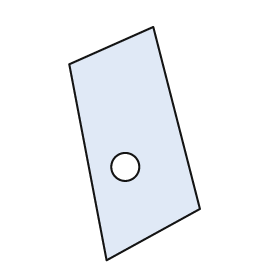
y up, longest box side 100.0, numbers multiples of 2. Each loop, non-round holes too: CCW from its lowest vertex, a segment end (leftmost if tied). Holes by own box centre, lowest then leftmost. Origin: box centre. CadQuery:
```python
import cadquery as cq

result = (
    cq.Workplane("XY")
    .moveTo(-12.0, -50.0)
    .lineTo(28.0, -28.0)
    .lineTo(8.0, 50.0)
    .lineTo(-28.0, 34.0)
    .close()
    .moveTo(-4.0, -10.0)
    .circle(6.0)
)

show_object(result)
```